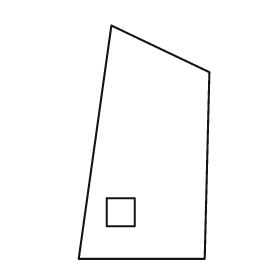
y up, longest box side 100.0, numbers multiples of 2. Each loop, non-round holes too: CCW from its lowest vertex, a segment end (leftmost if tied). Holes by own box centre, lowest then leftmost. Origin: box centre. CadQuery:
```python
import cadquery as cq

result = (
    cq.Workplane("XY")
    .moveTo(-28.0, -50.0)
    .lineTo(26.0, -50.0)
    .lineTo(28.0, 30.0)
    .lineTo(-14.0, 50.0)
    .close()
    .moveTo(-16.0, -36.0)
    .lineTo(-4.0, -36.0)
    .lineTo(-4.0, -24.0)
    .lineTo(-16.0, -24.0)
    .close()
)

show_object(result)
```